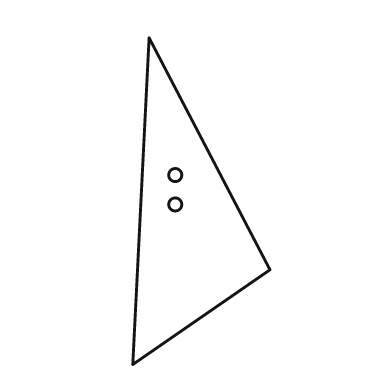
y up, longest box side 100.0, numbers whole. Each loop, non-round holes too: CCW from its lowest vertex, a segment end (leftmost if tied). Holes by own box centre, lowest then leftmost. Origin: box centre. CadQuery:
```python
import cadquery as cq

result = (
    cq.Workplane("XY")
    .moveTo(-21.0, -50.0)
    .lineTo(21.0, -21.0)
    .lineTo(-16.0, 50.0)
    .close()
    .moveTo(-8.0, -1.0)
    .circle(2.0)
    .moveTo(-8.0, 8.0)
    .circle(2.0)
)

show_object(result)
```